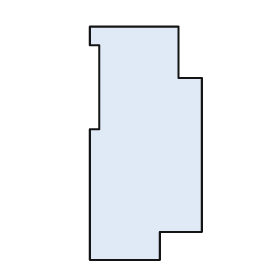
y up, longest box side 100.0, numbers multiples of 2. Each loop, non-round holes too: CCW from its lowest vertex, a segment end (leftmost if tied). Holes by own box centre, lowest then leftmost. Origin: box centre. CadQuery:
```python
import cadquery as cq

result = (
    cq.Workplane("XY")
    .moveTo(-24.0, -50.0)
    .lineTo(6.0, -50.0)
    .lineTo(6.0, -38.0)
    .lineTo(24.0, -38.0)
    .lineTo(24.0, 28.0)
    .lineTo(14.0, 28.0)
    .lineTo(14.0, 50.0)
    .lineTo(-24.0, 50.0)
    .lineTo(-24.0, 42.0)
    .lineTo(-20.0, 42.0)
    .lineTo(-20.0, 6.0)
    .lineTo(-24.0, 6.0)
    .close()
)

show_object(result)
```